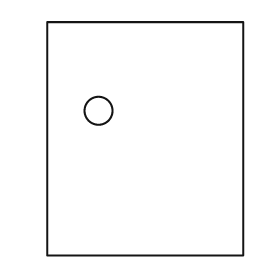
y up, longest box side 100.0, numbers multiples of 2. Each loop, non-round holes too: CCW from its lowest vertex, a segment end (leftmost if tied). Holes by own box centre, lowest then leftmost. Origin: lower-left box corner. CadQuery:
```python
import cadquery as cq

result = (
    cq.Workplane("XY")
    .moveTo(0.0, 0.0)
    .lineTo(84.0, 0.0)
    .lineTo(84.0, 100.0)
    .lineTo(0.0, 100.0)
    .close()
    .moveTo(22.0, 62.0)
    .circle(6.0)
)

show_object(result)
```